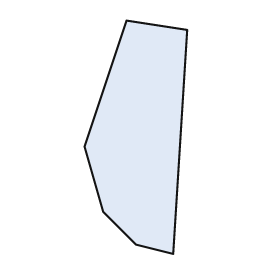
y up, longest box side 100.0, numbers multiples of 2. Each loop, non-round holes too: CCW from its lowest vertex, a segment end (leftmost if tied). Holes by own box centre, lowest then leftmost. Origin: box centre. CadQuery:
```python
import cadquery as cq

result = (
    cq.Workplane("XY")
    .moveTo(16.0, -50.0)
    .lineTo(22.0, 46.0)
    .lineTo(-4.0, 50.0)
    .lineTo(-22.0, -4.0)
    .lineTo(-14.0, -32.0)
    .lineTo(0.0, -46.0)
    .close()
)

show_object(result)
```